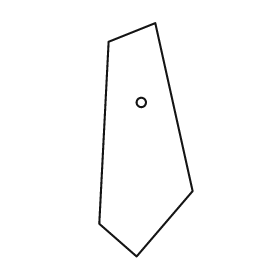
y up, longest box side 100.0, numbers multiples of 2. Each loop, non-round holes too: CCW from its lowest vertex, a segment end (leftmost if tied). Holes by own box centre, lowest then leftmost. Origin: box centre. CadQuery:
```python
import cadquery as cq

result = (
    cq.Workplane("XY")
    .moveTo(-4.0, -50.0)
    .lineTo(20.0, -22.0)
    .lineTo(4.0, 50.0)
    .lineTo(-16.0, 42.0)
    .lineTo(-20.0, -36.0)
    .close()
    .moveTo(-2.0, 16.0)
    .circle(2.0)
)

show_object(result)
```